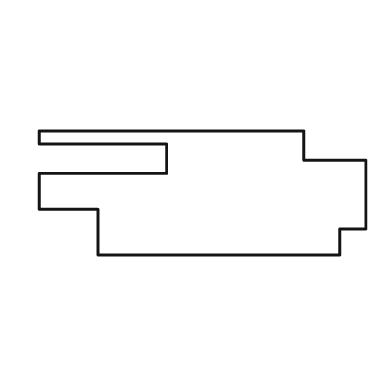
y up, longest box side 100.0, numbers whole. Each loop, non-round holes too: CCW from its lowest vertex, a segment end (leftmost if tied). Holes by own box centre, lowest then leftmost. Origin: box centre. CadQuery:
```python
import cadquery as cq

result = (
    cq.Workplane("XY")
    .moveTo(-32.0, -19.0)
    .lineTo(42.0, -19.0)
    .lineTo(42.0, -11.0)
    .lineTo(50.0, -11.0)
    .lineTo(50.0, 10.0)
    .lineTo(31.0, 10.0)
    .lineTo(31.0, 19.0)
    .lineTo(-50.0, 19.0)
    .lineTo(-50.0, 15.0)
    .lineTo(-11.0, 15.0)
    .lineTo(-11.0, 6.0)
    .lineTo(-50.0, 6.0)
    .lineTo(-50.0, -5.0)
    .lineTo(-32.0, -5.0)
    .close()
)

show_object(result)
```